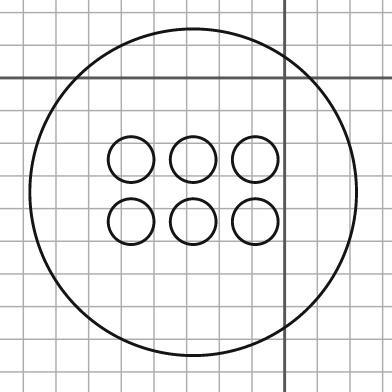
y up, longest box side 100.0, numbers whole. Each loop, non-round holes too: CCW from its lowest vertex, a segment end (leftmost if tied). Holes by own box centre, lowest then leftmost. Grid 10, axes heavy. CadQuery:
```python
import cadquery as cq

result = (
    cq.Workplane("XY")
    .moveTo(-28.0, -35.0)
    .circle(50.0)
    .moveTo(-47.0, -44.0)
    .circle(7.0)
    .moveTo(-28.0, -44.0)
    .circle(7.0)
    .moveTo(-9.0, -44.0)
    .circle(7.0)
    .moveTo(-47.0, -25.0)
    .circle(7.0)
    .moveTo(-28.0, -25.0)
    .circle(7.0)
    .moveTo(-9.0, -25.0)
    .circle(7.0)
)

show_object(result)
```